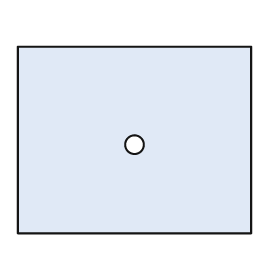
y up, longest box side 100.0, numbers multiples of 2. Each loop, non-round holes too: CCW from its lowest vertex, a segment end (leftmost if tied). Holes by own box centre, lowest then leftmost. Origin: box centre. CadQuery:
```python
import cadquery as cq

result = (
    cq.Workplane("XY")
    .moveTo(-50.0, -40.0)
    .lineTo(50.0, -40.0)
    .lineTo(50.0, 40.0)
    .lineTo(-50.0, 40.0)
    .close()
    .moveTo(0.0, -2.0)
    .circle(4.0)
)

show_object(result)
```